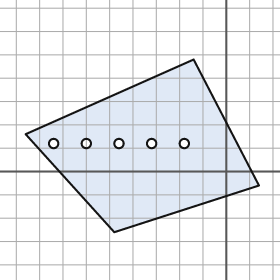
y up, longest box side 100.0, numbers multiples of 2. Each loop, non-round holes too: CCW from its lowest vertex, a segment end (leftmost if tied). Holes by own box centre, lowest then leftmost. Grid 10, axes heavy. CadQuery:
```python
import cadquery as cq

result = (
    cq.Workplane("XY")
    .moveTo(-48.0, -26.0)
    .lineTo(14.0, -6.0)
    .lineTo(-14.0, 48.0)
    .lineTo(-86.0, 16.0)
    .close()
    .moveTo(-74.0, 12.0)
    .circle(2.0)
    .moveTo(-60.0, 12.0)
    .circle(2.0)
    .moveTo(-46.0, 12.0)
    .circle(2.0)
    .moveTo(-32.0, 12.0)
    .circle(2.0)
    .moveTo(-18.0, 12.0)
    .circle(2.0)
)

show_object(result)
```